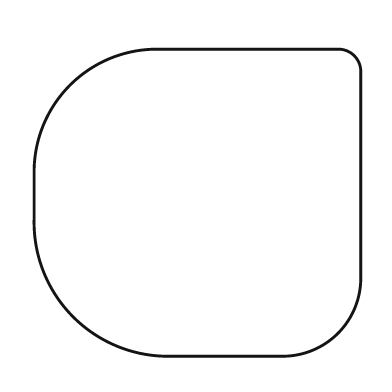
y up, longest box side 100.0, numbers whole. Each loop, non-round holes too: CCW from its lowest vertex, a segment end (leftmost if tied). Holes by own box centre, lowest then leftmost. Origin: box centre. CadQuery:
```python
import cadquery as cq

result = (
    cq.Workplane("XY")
    .moveTo(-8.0, -47.0)
    .lineTo(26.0, -47.0)
    .threePointArc((43.0, -40.0), (50.0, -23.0))
    .lineTo(50.0, 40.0)
    .threePointArc((48.0, 45.0), (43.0, 47.0))
    .lineTo(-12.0, 47.0)
    .threePointArc((-39.0, 36.0), (-50.0, 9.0))
    .lineTo(-50.0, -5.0)
    .threePointArc((-38.0, -35.0), (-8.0, -47.0))
    .close()
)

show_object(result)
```